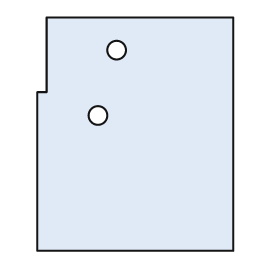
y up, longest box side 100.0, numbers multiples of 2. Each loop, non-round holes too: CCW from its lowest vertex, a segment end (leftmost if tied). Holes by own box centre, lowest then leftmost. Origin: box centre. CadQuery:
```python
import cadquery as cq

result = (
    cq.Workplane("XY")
    .moveTo(-42.0, -50.0)
    .lineTo(42.0, -50.0)
    .lineTo(42.0, 50.0)
    .lineTo(-38.0, 50.0)
    .lineTo(-38.0, 18.0)
    .lineTo(-42.0, 18.0)
    .close()
    .moveTo(-16.0, 8.0)
    .circle(4.0)
    .moveTo(-8.0, 36.0)
    .circle(4.0)
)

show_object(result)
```